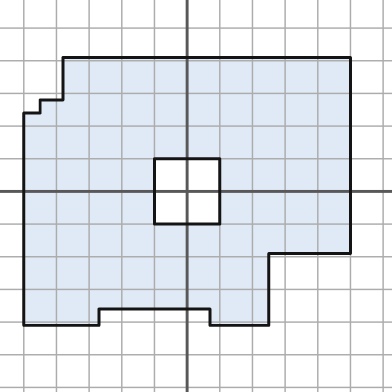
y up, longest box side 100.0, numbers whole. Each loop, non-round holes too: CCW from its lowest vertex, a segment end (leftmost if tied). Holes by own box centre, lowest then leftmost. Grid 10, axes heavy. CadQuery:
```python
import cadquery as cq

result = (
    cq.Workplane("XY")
    .moveTo(-50.0, -41.0)
    .lineTo(-27.0, -41.0)
    .lineTo(-27.0, -36.0)
    .lineTo(7.0, -36.0)
    .lineTo(7.0, -41.0)
    .lineTo(25.0, -41.0)
    .lineTo(25.0, -19.0)
    .lineTo(50.0, -19.0)
    .lineTo(50.0, 41.0)
    .lineTo(-38.0, 41.0)
    .lineTo(-38.0, 28.0)
    .lineTo(-45.0, 28.0)
    .lineTo(-45.0, 24.0)
    .lineTo(-50.0, 24.0)
    .close()
    .moveTo(-10.0, -10.0)
    .lineTo(10.0, -10.0)
    .lineTo(10.0, 10.0)
    .lineTo(-10.0, 10.0)
    .close()
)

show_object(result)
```